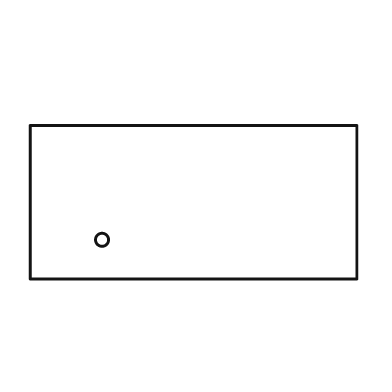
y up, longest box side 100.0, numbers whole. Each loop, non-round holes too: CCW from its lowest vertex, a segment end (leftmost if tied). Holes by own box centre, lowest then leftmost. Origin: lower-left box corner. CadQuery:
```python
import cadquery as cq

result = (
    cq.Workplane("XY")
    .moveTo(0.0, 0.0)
    .lineTo(100.0, 0.0)
    .lineTo(100.0, 47.0)
    .lineTo(0.0, 47.0)
    .close()
    .moveTo(22.0, 12.0)
    .circle(2.0)
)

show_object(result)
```